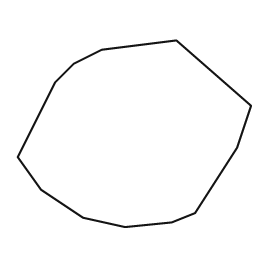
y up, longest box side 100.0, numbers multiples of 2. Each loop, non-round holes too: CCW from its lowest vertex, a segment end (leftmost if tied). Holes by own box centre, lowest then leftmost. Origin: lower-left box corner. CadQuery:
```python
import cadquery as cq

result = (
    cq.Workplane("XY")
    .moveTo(46.0, 0.0)
    .lineTo(66.0, 2.0)
    .lineTo(76.0, 6.0)
    .lineTo(94.0, 34.0)
    .lineTo(100.0, 52.0)
    .lineTo(68.0, 80.0)
    .lineTo(36.0, 76.0)
    .lineTo(24.0, 70.0)
    .lineTo(16.0, 62.0)
    .lineTo(0.0, 30.0)
    .lineTo(10.0, 16.0)
    .lineTo(28.0, 4.0)
    .close()
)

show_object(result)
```